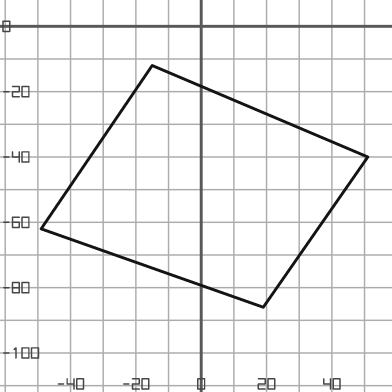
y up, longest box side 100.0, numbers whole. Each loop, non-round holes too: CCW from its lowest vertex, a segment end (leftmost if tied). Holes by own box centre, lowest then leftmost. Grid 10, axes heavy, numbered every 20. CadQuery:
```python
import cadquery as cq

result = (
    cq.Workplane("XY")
    .moveTo(19.0, -86.0)
    .lineTo(51.0, -40.0)
    .lineTo(-15.0, -12.0)
    .lineTo(-49.0, -62.0)
    .close()
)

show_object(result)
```